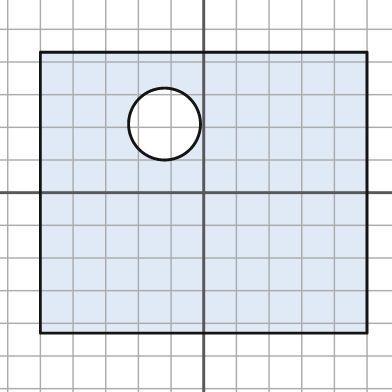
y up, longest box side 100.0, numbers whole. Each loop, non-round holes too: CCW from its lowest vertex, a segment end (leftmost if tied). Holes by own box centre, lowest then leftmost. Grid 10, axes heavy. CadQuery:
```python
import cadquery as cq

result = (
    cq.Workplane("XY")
    .moveTo(-50.0, -43.0)
    .lineTo(50.0, -43.0)
    .lineTo(50.0, 43.0)
    .lineTo(-50.0, 43.0)
    .close()
    .moveTo(-12.0, 21.0)
    .circle(11.0)
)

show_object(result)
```